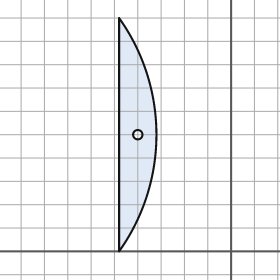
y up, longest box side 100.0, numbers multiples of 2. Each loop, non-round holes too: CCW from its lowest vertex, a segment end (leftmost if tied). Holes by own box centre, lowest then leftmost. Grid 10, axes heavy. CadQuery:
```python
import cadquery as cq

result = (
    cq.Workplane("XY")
    .moveTo(-48.0, 0.0)
    .threePointArc((-32.0, 50.0), (-48.0, 100.0))
    .close()
    .moveTo(-40.0, 50.0)
    .circle(2.0)
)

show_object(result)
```